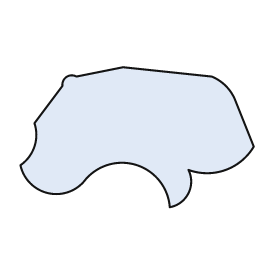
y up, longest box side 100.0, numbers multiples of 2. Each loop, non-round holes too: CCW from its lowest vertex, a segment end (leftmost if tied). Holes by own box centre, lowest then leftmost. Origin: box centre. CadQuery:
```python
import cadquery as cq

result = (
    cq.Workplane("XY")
    .moveTo(14.0, -30.0)
    .threePointArc((22.0, -24.0), (22.0, -14.0))
    .threePointArc((38.0, -14.0), (50.0, -4.0))
    .lineTo(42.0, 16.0)
    .threePointArc((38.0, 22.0), (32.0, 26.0))
    .lineTo(-6.0, 30.0)
    .lineTo(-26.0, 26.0)
    .threePointArc((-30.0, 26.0), (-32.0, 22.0))
    .lineTo(-44.0, 6.0)
    .threePointArc((-44.0, -4.0), (-50.0, -12.0))
    .threePointArc((-38.0, -24.0), (-22.0, -18.0))
    .threePointArc((0.0, -12.0), (14.0, -30.0))
    .close()
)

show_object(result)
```